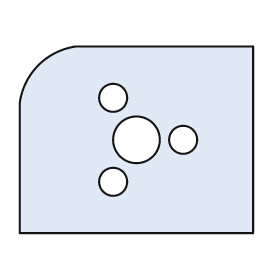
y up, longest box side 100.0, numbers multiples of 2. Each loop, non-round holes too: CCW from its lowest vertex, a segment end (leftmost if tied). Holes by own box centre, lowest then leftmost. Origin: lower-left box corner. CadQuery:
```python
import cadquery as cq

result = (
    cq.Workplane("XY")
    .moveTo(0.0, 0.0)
    .lineTo(100.0, 0.0)
    .lineTo(100.0, 80.0)
    .lineTo(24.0, 80.0)
    .threePointArc((8.0, 72.0), (0.0, 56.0))
    .close()
    .moveTo(40.0, 22.0)
    .circle(6.0)
    .moveTo(50.0, 40.0)
    .circle(10.0)
    .moveTo(70.0, 40.0)
    .circle(6.0)
    .moveTo(40.0, 58.0)
    .circle(6.0)
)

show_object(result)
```